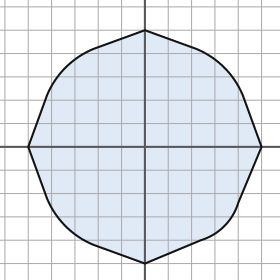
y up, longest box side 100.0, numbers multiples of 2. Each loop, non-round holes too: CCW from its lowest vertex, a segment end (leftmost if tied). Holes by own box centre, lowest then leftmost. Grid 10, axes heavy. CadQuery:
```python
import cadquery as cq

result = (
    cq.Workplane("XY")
    .moveTo(0.0, -50.0)
    .lineTo(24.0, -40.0)
    .threePointArc((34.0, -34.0), (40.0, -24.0))
    .lineTo(50.0, 0.0)
    .lineTo(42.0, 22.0)
    .threePointArc((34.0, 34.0), (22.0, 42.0))
    .lineTo(0.0, 50.0)
    .lineTo(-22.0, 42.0)
    .threePointArc((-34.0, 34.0), (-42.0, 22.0))
    .lineTo(-50.0, 0.0)
    .lineTo(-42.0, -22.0)
    .threePointArc((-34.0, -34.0), (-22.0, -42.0))
    .close()
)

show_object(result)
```